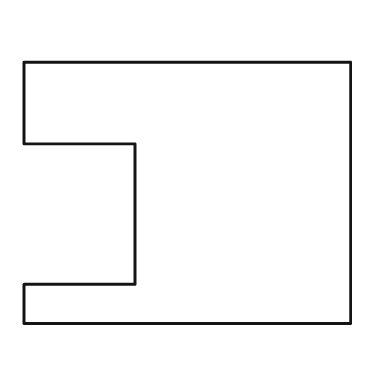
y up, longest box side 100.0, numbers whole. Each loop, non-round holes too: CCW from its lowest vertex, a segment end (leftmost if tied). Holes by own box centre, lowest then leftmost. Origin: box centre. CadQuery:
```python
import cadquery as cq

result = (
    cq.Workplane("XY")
    .moveTo(-50.0, -40.0)
    .lineTo(50.0, -40.0)
    .lineTo(50.0, 40.0)
    .lineTo(-50.0, 40.0)
    .lineTo(-50.0, 15.0)
    .lineTo(-16.0, 15.0)
    .lineTo(-16.0, -28.0)
    .lineTo(-50.0, -28.0)
    .close()
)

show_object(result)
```